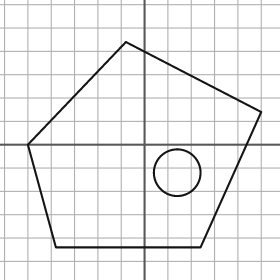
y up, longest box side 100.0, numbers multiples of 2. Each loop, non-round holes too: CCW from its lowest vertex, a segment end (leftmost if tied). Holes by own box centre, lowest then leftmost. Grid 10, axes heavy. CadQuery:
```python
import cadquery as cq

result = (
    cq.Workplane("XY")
    .moveTo(-38.0, -44.0)
    .lineTo(24.0, -44.0)
    .lineTo(50.0, 14.0)
    .lineTo(-8.0, 44.0)
    .lineTo(-50.0, 0.0)
    .close()
    .moveTo(14.0, -12.0)
    .circle(10.0)
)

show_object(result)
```